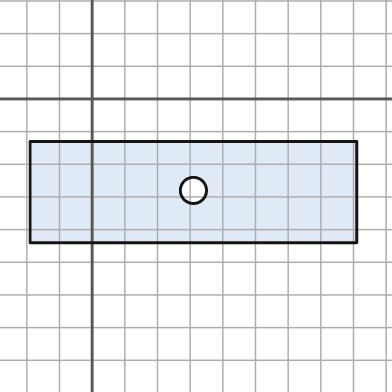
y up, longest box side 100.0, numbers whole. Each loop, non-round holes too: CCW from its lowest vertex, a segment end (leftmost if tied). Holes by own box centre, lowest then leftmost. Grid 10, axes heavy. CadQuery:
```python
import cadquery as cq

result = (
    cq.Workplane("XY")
    .moveTo(-19.0, -44.0)
    .lineTo(81.0, -44.0)
    .lineTo(81.0, -13.0)
    .lineTo(-19.0, -13.0)
    .close()
    .moveTo(31.0, -28.0)
    .circle(4.0)
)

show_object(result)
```